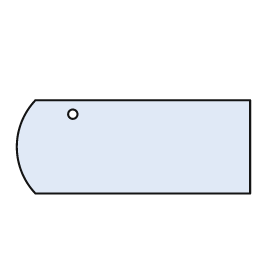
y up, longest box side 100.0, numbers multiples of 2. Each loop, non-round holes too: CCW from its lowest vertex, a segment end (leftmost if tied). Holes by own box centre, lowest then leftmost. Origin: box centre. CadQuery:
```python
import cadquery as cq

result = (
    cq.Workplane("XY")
    .moveTo(-42.0, -20.0)
    .lineTo(50.0, -20.0)
    .lineTo(50.0, 20.0)
    .lineTo(-42.0, 20.0)
    .threePointArc((-50.0, 0.0), (-42.0, -20.0))
    .close()
    .moveTo(-26.0, 14.0)
    .circle(2.0)
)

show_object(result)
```